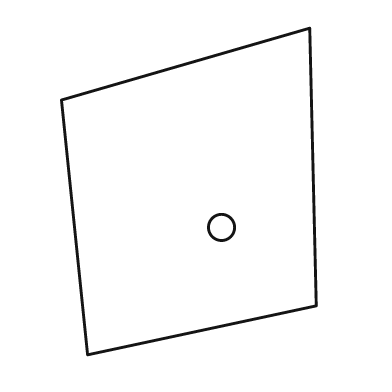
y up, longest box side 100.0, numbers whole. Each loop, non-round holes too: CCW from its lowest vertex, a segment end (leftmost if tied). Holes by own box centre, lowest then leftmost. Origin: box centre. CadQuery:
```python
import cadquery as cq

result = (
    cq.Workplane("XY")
    .moveTo(-31.0, -50.0)
    .lineTo(39.0, -35.0)
    .lineTo(37.0, 50.0)
    .lineTo(-39.0, 28.0)
    .close()
    .moveTo(10.0, -11.0)
    .circle(4.0)
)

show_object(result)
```